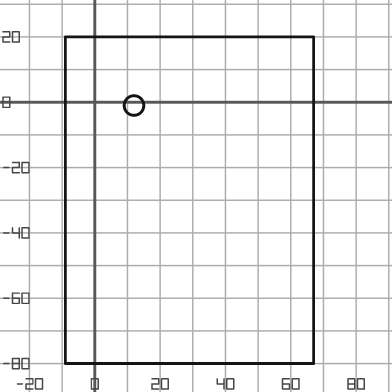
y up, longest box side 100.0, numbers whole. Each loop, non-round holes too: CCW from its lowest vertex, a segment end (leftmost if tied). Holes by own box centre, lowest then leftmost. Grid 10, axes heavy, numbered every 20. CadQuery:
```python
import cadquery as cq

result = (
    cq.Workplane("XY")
    .moveTo(-9.0, -80.0)
    .lineTo(67.0, -80.0)
    .lineTo(67.0, 20.0)
    .lineTo(-9.0, 20.0)
    .close()
    .moveTo(12.0, -1.0)
    .circle(3.0)
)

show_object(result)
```